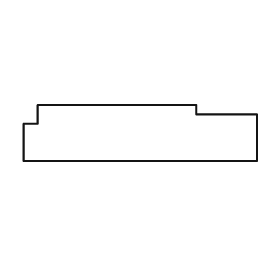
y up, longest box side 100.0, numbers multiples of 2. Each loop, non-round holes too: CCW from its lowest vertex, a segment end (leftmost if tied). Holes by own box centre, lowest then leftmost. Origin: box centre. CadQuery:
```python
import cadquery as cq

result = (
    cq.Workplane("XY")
    .moveTo(-50.0, -12.0)
    .lineTo(50.0, -12.0)
    .lineTo(50.0, 8.0)
    .lineTo(24.0, 8.0)
    .lineTo(24.0, 12.0)
    .lineTo(-44.0, 12.0)
    .lineTo(-44.0, 4.0)
    .lineTo(-50.0, 4.0)
    .close()
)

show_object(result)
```